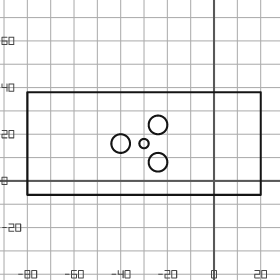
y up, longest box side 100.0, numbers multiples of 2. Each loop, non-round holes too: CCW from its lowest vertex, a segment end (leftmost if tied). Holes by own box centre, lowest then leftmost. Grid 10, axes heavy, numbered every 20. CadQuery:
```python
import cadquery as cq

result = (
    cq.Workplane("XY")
    .moveTo(-80.0, -6.0)
    .lineTo(20.0, -6.0)
    .lineTo(20.0, 38.0)
    .lineTo(-80.0, 38.0)
    .close()
    .moveTo(-24.0, 8.0)
    .circle(4.0)
    .moveTo(-40.0, 16.0)
    .circle(4.0)
    .moveTo(-30.0, 16.0)
    .circle(2.0)
    .moveTo(-24.0, 24.0)
    .circle(4.0)
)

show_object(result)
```